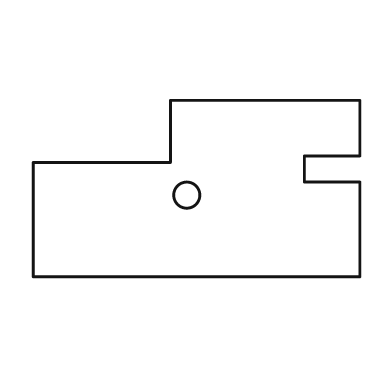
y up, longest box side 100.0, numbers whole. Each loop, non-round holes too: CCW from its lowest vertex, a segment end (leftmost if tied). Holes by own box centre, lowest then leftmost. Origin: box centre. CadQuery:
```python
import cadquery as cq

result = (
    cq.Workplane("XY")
    .moveTo(-50.0, -27.0)
    .lineTo(50.0, -27.0)
    .lineTo(50.0, 2.0)
    .lineTo(33.0, 2.0)
    .lineTo(33.0, 10.0)
    .lineTo(50.0, 10.0)
    .lineTo(50.0, 27.0)
    .lineTo(-8.0, 27.0)
    .lineTo(-8.0, 8.0)
    .lineTo(-50.0, 8.0)
    .close()
    .moveTo(-3.0, -2.0)
    .circle(4.0)
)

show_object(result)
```